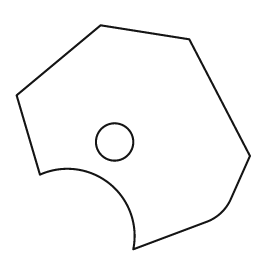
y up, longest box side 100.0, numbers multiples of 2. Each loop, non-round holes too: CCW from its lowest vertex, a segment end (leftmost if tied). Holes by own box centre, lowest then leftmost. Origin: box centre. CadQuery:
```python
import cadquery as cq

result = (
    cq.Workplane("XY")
    .moveTo(0.0, -48.0)
    .lineTo(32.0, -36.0)
    .threePointArc((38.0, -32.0), (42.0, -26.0))
    .lineTo(50.0, -8.0)
    .lineTo(24.0, 42.0)
    .lineTo(-14.0, 48.0)
    .lineTo(-50.0, 18.0)
    .lineTo(-40.0, -16.0)
    .threePointArc((-10.0, -20.0), (0.0, -48.0))
    .close()
    .moveTo(-8.0, -2.0)
    .circle(8.0)
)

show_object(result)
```